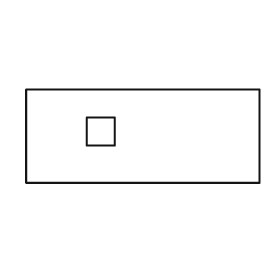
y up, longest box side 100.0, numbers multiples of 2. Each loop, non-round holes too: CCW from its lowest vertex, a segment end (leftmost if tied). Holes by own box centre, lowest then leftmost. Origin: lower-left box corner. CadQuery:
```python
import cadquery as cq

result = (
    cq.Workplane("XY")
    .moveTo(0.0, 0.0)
    .lineTo(100.0, 0.0)
    .lineTo(100.0, 40.0)
    .lineTo(0.0, 40.0)
    .close()
    .moveTo(26.0, 16.0)
    .lineTo(38.0, 16.0)
    .lineTo(38.0, 28.0)
    .lineTo(26.0, 28.0)
    .close()
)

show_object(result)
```